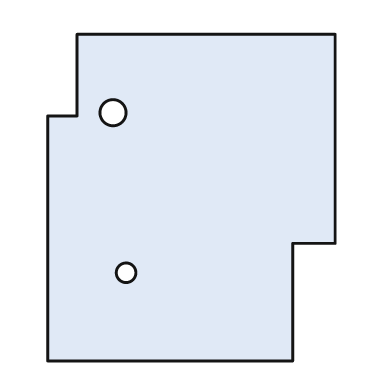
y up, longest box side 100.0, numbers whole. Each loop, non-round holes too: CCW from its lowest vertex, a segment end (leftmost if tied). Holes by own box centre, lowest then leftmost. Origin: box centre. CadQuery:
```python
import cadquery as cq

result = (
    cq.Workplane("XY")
    .moveTo(-44.0, -50.0)
    .lineTo(31.0, -50.0)
    .lineTo(31.0, -14.0)
    .lineTo(44.0, -14.0)
    .lineTo(44.0, 50.0)
    .lineTo(-35.0, 50.0)
    .lineTo(-35.0, 25.0)
    .lineTo(-44.0, 25.0)
    .close()
    .moveTo(-20.0, -23.0)
    .circle(3.0)
    .moveTo(-24.0, 26.0)
    .circle(4.0)
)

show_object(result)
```